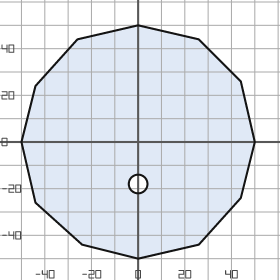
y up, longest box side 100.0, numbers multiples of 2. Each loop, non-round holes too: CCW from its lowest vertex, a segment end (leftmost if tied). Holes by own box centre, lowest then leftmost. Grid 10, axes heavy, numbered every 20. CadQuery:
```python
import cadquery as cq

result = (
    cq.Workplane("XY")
    .moveTo(0.0, -50.0)
    .lineTo(26.0, -44.0)
    .lineTo(44.0, -24.0)
    .lineTo(50.0, 0.0)
    .lineTo(44.0, 26.0)
    .lineTo(26.0, 44.0)
    .lineTo(0.0, 50.0)
    .lineTo(-26.0, 44.0)
    .lineTo(-44.0, 24.0)
    .lineTo(-50.0, 0.0)
    .lineTo(-44.0, -26.0)
    .lineTo(-24.0, -44.0)
    .close()
    .moveTo(0.0, -18.0)
    .circle(4.0)
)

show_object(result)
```